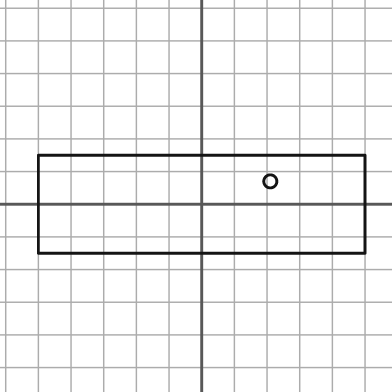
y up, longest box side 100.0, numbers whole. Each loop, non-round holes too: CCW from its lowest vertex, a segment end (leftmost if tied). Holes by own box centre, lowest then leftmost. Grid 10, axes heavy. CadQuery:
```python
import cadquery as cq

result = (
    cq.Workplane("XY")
    .moveTo(-50.0, -15.0)
    .lineTo(50.0, -15.0)
    .lineTo(50.0, 15.0)
    .lineTo(-50.0, 15.0)
    .close()
    .moveTo(21.0, 7.0)
    .circle(2.0)
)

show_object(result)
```